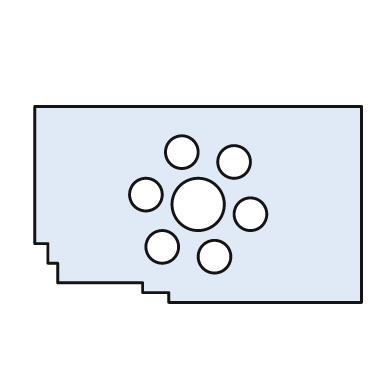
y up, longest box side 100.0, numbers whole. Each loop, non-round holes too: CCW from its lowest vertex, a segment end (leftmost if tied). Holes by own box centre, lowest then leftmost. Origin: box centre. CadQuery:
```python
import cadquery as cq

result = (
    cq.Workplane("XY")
    .moveTo(-9.0, -30.0)
    .lineTo(50.0, -30.0)
    .lineTo(50.0, 30.0)
    .lineTo(-50.0, 30.0)
    .lineTo(-50.0, -12.0)
    .lineTo(-46.0, -12.0)
    .lineTo(-46.0, -18.0)
    .lineTo(-43.0, -18.0)
    .lineTo(-43.0, -24.0)
    .lineTo(-17.0, -24.0)
    .lineTo(-17.0, -27.0)
    .lineTo(-9.0, -27.0)
    .close()
    .moveTo(5.0, -16.0)
    .circle(5.0)
    .moveTo(-11.0, -13.0)
    .circle(5.0)
    .moveTo(16.0, -3.0)
    .circle(5.0)
    .moveTo(0.0, 0.0)
    .circle(8.0)
    .moveTo(-16.0, 3.0)
    .circle(5.0)
    .moveTo(11.0, 13.0)
    .circle(5.0)
    .moveTo(-5.0, 16.0)
    .circle(5.0)
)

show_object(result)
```